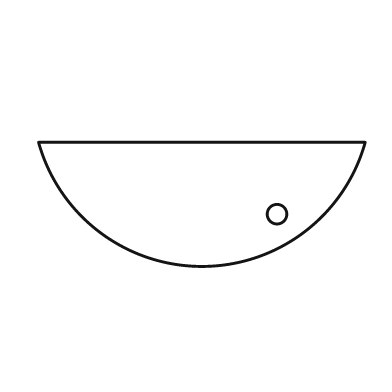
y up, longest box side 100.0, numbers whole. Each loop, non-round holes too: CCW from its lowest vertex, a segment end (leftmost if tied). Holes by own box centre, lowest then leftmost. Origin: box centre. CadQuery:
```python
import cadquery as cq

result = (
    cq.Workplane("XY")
    .moveTo(-50.0, 19.0)
    .threePointArc((0.0, -19.0), (50.0, 19.0))
    .close()
    .moveTo(23.0, -3.0)
    .circle(3.0)
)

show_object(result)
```